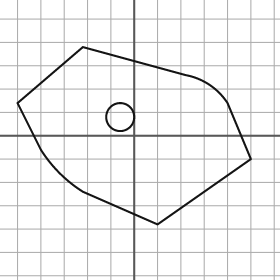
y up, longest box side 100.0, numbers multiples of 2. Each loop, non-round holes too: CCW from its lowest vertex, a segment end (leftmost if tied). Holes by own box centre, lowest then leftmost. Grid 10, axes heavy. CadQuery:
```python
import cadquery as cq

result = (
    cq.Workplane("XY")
    .moveTo(10.0, -38.0)
    .lineTo(50.0, -10.0)
    .lineTo(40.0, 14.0)
    .threePointArc((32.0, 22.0), (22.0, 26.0))
    .lineTo(-22.0, 38.0)
    .lineTo(-50.0, 14.0)
    .lineTo(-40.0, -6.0)
    .threePointArc((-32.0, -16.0), (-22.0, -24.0))
    .close()
    .moveTo(-6.0, 8.0)
    .circle(6.0)
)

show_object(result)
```